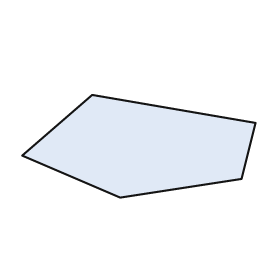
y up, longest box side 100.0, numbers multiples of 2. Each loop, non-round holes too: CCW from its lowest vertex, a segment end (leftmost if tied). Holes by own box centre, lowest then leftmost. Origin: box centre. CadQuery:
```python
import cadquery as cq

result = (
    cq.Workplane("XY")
    .moveTo(-8.0, -22.0)
    .lineTo(44.0, -14.0)
    .lineTo(50.0, 10.0)
    .lineTo(-20.0, 22.0)
    .lineTo(-50.0, -4.0)
    .close()
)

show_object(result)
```